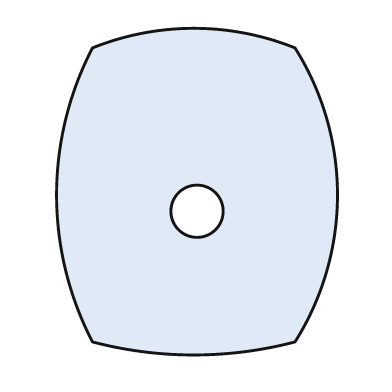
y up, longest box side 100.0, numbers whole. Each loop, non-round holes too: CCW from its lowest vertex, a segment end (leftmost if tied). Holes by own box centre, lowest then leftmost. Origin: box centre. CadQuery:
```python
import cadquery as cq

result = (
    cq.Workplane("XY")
    .moveTo(-32.0, -46.0)
    .threePointArc((-1.0, -50.0), (30.0, -46.0))
    .threePointArc((43.0, -1.0), (30.0, 44.0))
    .threePointArc((-1.0, 50.0), (-32.0, 44.0))
    .threePointArc((-43.0, -1.0), (-32.0, -46.0))
    .close()
    .moveTo(0.0, -6.0)
    .circle(8.0)
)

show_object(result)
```